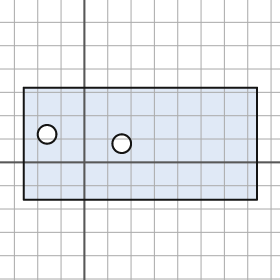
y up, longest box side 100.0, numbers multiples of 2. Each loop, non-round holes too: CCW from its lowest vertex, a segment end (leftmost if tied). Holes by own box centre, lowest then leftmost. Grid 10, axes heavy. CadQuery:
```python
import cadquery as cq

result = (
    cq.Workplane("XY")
    .moveTo(-26.0, -16.0)
    .lineTo(74.0, -16.0)
    .lineTo(74.0, 32.0)
    .lineTo(-26.0, 32.0)
    .close()
    .moveTo(16.0, 8.0)
    .circle(4.0)
    .moveTo(-16.0, 12.0)
    .circle(4.0)
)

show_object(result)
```